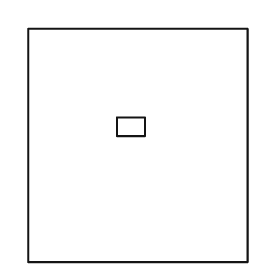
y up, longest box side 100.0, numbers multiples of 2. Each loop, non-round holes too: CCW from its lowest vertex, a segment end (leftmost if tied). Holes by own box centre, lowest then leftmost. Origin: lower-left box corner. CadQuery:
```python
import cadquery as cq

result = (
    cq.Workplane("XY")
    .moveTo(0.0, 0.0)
    .lineTo(94.0, 0.0)
    .lineTo(94.0, 100.0)
    .lineTo(0.0, 100.0)
    .close()
    .moveTo(38.0, 54.0)
    .lineTo(50.0, 54.0)
    .lineTo(50.0, 62.0)
    .lineTo(38.0, 62.0)
    .close()
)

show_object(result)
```